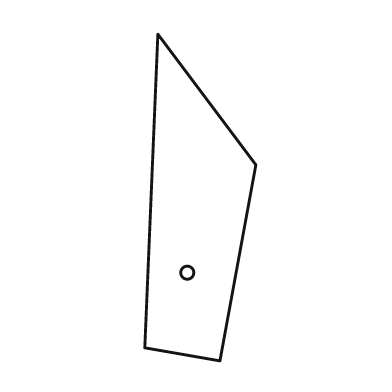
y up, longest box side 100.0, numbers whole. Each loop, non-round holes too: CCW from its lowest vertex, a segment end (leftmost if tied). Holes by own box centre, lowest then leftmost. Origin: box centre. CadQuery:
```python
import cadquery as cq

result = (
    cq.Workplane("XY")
    .moveTo(6.0, -50.0)
    .lineTo(17.0, 10.0)
    .lineTo(-13.0, 50.0)
    .lineTo(-17.0, -46.0)
    .close()
    .moveTo(-4.0, -23.0)
    .circle(2.0)
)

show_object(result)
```